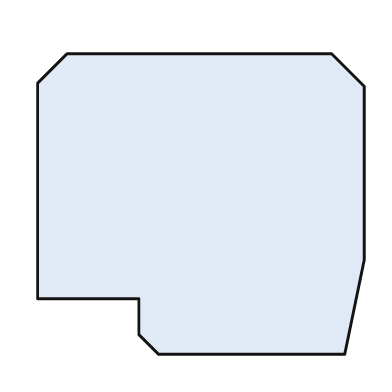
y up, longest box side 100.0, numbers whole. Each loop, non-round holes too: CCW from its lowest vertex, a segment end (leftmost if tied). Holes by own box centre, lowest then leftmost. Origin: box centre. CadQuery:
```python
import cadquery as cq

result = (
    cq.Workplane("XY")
    .moveTo(-13.0, -46.0)
    .lineTo(44.0, -46.0)
    .lineTo(50.0, -17.0)
    .lineTo(50.0, 36.0)
    .lineTo(40.0, 46.0)
    .lineTo(-41.0, 46.0)
    .lineTo(-50.0, 37.0)
    .lineTo(-50.0, -29.0)
    .lineTo(-19.0, -29.0)
    .lineTo(-19.0, -40.0)
    .close()
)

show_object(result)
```